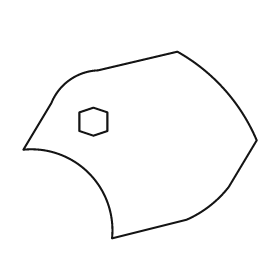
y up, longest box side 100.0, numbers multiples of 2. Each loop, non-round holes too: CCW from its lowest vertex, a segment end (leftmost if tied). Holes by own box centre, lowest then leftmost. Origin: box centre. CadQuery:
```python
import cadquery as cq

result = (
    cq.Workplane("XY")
    .moveTo(-12.0, -40.0)
    .lineTo(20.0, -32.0)
    .threePointArc((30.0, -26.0), (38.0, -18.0))
    .lineTo(50.0, 2.0)
    .threePointArc((36.0, 24.0), (16.0, 40.0))
    .lineTo(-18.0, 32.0)
    .threePointArc((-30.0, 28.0), (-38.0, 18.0))
    .lineTo(-50.0, -2.0)
    .threePointArc((-22.0, -12.0), (-12.0, -40.0))
    .close()
    .moveTo(-20.0, 4.0)
    .lineTo(-14.0, 6.0)
    .lineTo(-14.0, 14.0)
    .lineTo(-20.0, 16.0)
    .lineTo(-26.0, 14.0)
    .lineTo(-26.0, 6.0)
    .close()
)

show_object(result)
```